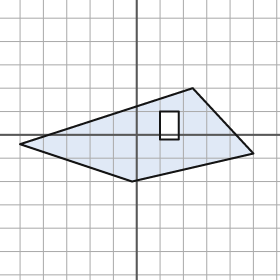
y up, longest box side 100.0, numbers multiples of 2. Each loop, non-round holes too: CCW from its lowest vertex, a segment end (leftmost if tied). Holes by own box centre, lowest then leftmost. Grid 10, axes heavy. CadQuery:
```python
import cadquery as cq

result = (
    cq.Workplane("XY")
    .moveTo(-2.0, -20.0)
    .lineTo(50.0, -8.0)
    .lineTo(24.0, 20.0)
    .lineTo(-50.0, -4.0)
    .close()
    .moveTo(10.0, -2.0)
    .lineTo(18.0, -2.0)
    .lineTo(18.0, 10.0)
    .lineTo(10.0, 10.0)
    .close()
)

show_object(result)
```